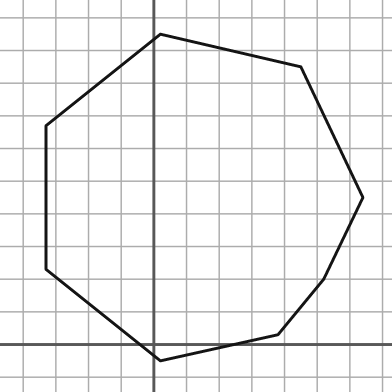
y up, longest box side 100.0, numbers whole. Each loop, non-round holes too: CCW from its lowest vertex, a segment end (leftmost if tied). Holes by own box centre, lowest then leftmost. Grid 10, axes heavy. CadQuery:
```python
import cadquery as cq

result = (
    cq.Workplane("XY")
    .moveTo(2.0, -5.0)
    .lineTo(38.0, 3.0)
    .lineTo(52.0, 20.0)
    .lineTo(64.0, 45.0)
    .lineTo(45.0, 85.0)
    .lineTo(2.0, 95.0)
    .lineTo(-33.0, 67.0)
    .lineTo(-33.0, 23.0)
    .close()
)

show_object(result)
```